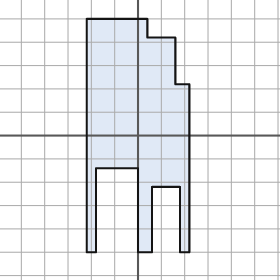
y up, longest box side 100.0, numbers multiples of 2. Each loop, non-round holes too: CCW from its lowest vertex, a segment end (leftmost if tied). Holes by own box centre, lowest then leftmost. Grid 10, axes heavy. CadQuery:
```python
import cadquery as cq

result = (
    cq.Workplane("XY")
    .moveTo(-22.0, -50.0)
    .lineTo(-18.0, -50.0)
    .lineTo(-18.0, -14.0)
    .lineTo(0.0, -14.0)
    .lineTo(0.0, -50.0)
    .lineTo(6.0, -50.0)
    .lineTo(6.0, -22.0)
    .lineTo(18.0, -22.0)
    .lineTo(18.0, -50.0)
    .lineTo(22.0, -50.0)
    .lineTo(22.0, 22.0)
    .lineTo(16.0, 22.0)
    .lineTo(16.0, 42.0)
    .lineTo(4.0, 42.0)
    .lineTo(4.0, 50.0)
    .lineTo(-22.0, 50.0)
    .close()
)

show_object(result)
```